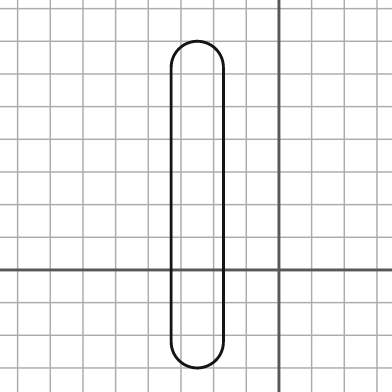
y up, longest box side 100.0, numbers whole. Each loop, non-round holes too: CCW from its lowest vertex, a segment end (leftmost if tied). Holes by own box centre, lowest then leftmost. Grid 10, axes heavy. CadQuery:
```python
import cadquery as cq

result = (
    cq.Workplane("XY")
    .moveTo(-33.0, -22.0)
    .threePointArc((-25.0, -30.0), (-17.0, -22.0))
    .lineTo(-17.0, 62.0)
    .threePointArc((-25.0, 70.0), (-33.0, 62.0))
    .close()
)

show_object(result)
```